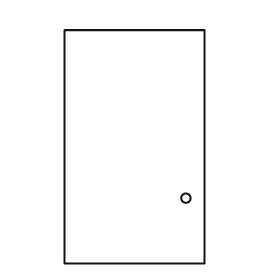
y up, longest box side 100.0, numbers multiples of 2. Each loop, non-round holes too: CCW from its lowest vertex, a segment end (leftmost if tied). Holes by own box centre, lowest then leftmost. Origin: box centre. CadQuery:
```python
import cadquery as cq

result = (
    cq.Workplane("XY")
    .moveTo(-30.0, -50.0)
    .lineTo(30.0, -50.0)
    .lineTo(30.0, 50.0)
    .lineTo(-30.0, 50.0)
    .close()
    .moveTo(22.0, -22.0)
    .circle(2.0)
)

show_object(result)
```